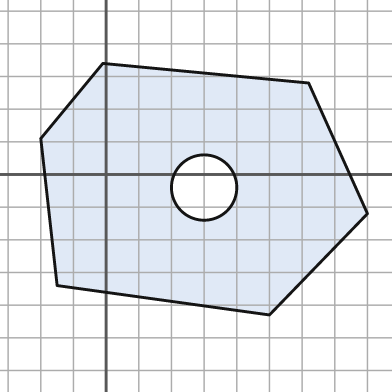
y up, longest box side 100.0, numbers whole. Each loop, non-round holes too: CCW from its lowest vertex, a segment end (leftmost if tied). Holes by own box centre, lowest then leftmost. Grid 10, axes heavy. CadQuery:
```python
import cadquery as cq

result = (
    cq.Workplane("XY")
    .moveTo(50.0, -43.0)
    .lineTo(80.0, -12.0)
    .lineTo(62.0, 28.0)
    .lineTo(-1.0, 34.0)
    .lineTo(-20.0, 11.0)
    .lineTo(-15.0, -34.0)
    .close()
    .moveTo(30.0, -4.0)
    .circle(10.0)
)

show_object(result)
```